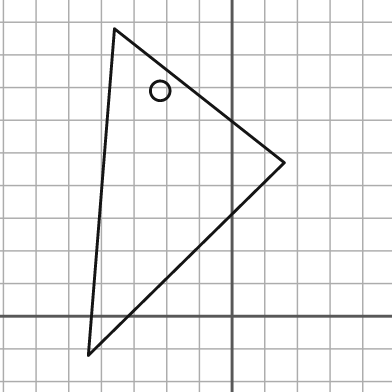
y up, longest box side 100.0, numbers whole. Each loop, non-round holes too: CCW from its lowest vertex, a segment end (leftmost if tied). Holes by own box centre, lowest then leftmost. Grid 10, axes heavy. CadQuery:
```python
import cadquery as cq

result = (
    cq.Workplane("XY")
    .moveTo(-44.0, -12.0)
    .lineTo(16.0, 47.0)
    .lineTo(-36.0, 88.0)
    .close()
    .moveTo(-22.0, 69.0)
    .circle(3.0)
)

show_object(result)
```